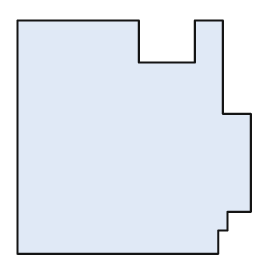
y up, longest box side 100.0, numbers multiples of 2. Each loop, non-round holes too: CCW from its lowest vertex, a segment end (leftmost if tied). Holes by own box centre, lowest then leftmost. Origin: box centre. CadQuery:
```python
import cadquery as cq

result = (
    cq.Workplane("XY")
    .moveTo(-50.0, -50.0)
    .lineTo(36.0, -50.0)
    .lineTo(36.0, -40.0)
    .lineTo(40.0, -40.0)
    .lineTo(40.0, -32.0)
    .lineTo(50.0, -32.0)
    .lineTo(50.0, 10.0)
    .lineTo(38.0, 10.0)
    .lineTo(38.0, 50.0)
    .lineTo(26.0, 50.0)
    .lineTo(26.0, 32.0)
    .lineTo(2.0, 32.0)
    .lineTo(2.0, 50.0)
    .lineTo(-50.0, 50.0)
    .close()
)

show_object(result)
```